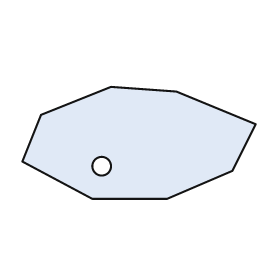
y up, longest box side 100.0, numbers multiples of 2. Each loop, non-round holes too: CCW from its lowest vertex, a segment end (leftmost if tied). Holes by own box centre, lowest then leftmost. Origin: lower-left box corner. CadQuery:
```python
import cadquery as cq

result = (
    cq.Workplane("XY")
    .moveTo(30.0, 0.0)
    .lineTo(62.0, 0.0)
    .lineTo(90.0, 12.0)
    .lineTo(100.0, 32.0)
    .lineTo(66.0, 46.0)
    .lineTo(38.0, 48.0)
    .lineTo(8.0, 36.0)
    .lineTo(0.0, 16.0)
    .close()
    .moveTo(34.0, 14.0)
    .circle(4.0)
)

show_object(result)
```